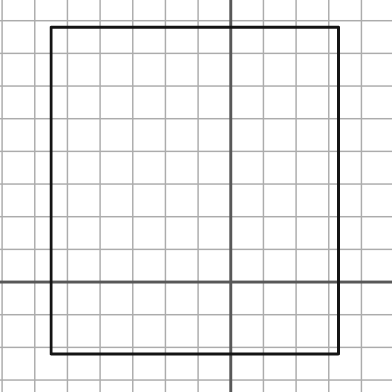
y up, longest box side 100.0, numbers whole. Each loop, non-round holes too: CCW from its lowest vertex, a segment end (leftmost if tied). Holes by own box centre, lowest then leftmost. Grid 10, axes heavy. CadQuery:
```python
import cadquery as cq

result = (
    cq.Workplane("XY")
    .moveTo(-55.0, -22.0)
    .lineTo(33.0, -22.0)
    .lineTo(33.0, 78.0)
    .lineTo(-55.0, 78.0)
    .close()
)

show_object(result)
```